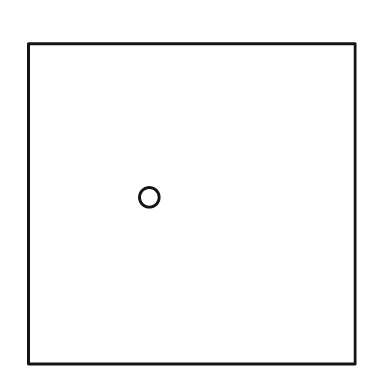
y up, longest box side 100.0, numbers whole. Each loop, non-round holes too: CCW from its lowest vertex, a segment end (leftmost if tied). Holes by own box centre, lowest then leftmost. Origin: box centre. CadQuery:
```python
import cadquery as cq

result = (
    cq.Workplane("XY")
    .moveTo(-50.0, -49.0)
    .lineTo(50.0, -49.0)
    .lineTo(50.0, 49.0)
    .lineTo(-50.0, 49.0)
    .close()
    .moveTo(-13.0, 2.0)
    .circle(3.0)
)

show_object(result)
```